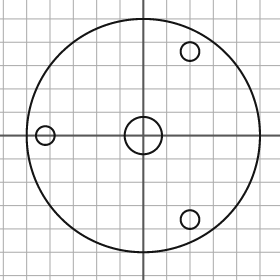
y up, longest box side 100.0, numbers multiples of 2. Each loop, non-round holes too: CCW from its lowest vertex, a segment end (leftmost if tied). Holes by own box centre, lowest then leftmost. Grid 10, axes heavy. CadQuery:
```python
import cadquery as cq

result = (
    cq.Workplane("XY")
    .moveTo(0.0, 0.0)
    .circle(50.0)
    .moveTo(20.0, -36.0)
    .circle(4.0)
    .moveTo(-42.0, 0.0)
    .circle(4.0)
    .moveTo(0.0, 0.0)
    .circle(8.0)
    .moveTo(20.0, 36.0)
    .circle(4.0)
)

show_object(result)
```